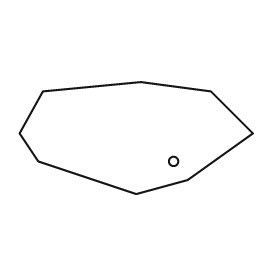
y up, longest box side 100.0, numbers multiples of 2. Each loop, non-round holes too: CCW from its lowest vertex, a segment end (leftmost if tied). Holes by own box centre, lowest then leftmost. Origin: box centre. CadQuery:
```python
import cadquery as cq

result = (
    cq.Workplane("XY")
    .moveTo(0.0, -24.0)
    .lineTo(22.0, -18.0)
    .lineTo(50.0, 2.0)
    .lineTo(32.0, 20.0)
    .lineTo(2.0, 24.0)
    .lineTo(-40.0, 20.0)
    .lineTo(-50.0, 2.0)
    .lineTo(-42.0, -10.0)
    .close()
    .moveTo(16.0, -10.0)
    .circle(2.0)
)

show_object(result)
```